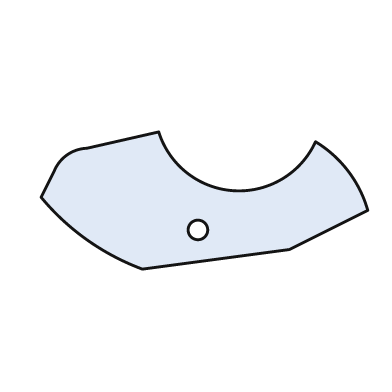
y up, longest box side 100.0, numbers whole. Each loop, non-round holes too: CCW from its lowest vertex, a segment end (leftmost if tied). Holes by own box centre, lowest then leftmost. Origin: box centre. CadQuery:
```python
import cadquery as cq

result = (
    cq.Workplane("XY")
    .moveTo(-19.0, -21.0)
    .lineTo(26.0, -15.0)
    .lineTo(50.0, -3.0)
    .threePointArc((44.0, 9.0), (34.0, 18.0))
    .threePointArc((9.0, 3.0), (-14.0, 21.0))
    .lineTo(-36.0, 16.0)
    .threePointArc((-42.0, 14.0), (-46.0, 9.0))
    .lineTo(-50.0, 1.0)
    .threePointArc((-36.0, -12.0), (-19.0, -21.0))
    .close()
    .moveTo(-2.0, -9.0)
    .circle(3.0)
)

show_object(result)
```